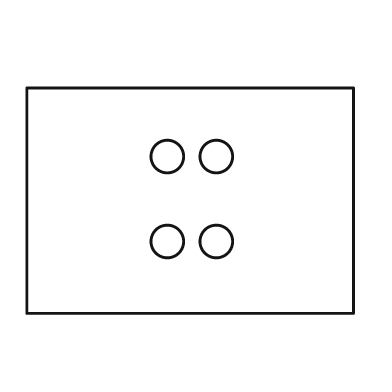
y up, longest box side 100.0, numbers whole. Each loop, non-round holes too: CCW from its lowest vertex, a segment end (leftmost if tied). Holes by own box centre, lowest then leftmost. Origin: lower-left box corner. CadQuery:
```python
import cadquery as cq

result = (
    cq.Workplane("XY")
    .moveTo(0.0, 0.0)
    .lineTo(100.0, 0.0)
    .lineTo(100.0, 69.0)
    .lineTo(0.0, 69.0)
    .close()
    .moveTo(43.0, 22.0)
    .circle(5.0)
    .moveTo(58.0, 22.0)
    .circle(5.0)
    .moveTo(43.0, 48.0)
    .circle(5.0)
    .moveTo(58.0, 48.0)
    .circle(5.0)
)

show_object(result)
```